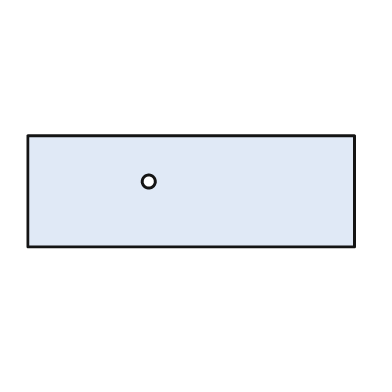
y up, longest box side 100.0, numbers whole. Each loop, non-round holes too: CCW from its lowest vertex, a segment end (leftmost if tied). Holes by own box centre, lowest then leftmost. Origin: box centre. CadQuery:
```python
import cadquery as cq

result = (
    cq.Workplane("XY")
    .moveTo(-50.0, -17.0)
    .lineTo(50.0, -17.0)
    .lineTo(50.0, 17.0)
    .lineTo(-50.0, 17.0)
    .close()
    .moveTo(-13.0, 3.0)
    .circle(2.0)
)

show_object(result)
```